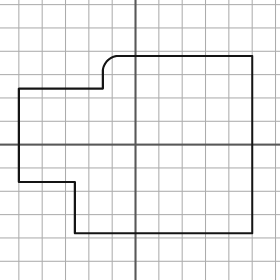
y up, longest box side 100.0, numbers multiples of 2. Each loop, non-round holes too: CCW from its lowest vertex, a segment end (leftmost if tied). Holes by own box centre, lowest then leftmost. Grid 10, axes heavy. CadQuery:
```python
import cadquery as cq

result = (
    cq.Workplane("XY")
    .moveTo(-26.0, -38.0)
    .lineTo(50.0, -38.0)
    .lineTo(50.0, 38.0)
    .lineTo(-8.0, 38.0)
    .threePointArc((-12.0, 36.0), (-14.0, 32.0))
    .lineTo(-14.0, 24.0)
    .lineTo(-50.0, 24.0)
    .lineTo(-50.0, -16.0)
    .lineTo(-26.0, -16.0)
    .close()
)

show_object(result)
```